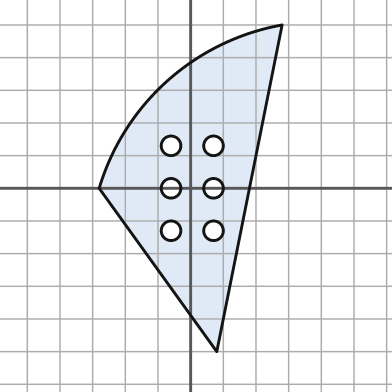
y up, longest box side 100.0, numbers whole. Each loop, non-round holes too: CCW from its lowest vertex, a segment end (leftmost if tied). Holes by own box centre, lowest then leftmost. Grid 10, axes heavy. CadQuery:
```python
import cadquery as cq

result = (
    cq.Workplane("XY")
    .moveTo(8.0, -50.0)
    .lineTo(28.0, 50.0)
    .threePointArc((-7.0, 33.0), (-28.0, 0.0))
    .close()
    .moveTo(-6.0, -13.0)
    .circle(3.0)
    .moveTo(7.0, -13.0)
    .circle(3.0)
    .moveTo(-6.0, 0.0)
    .circle(3.0)
    .moveTo(7.0, 0.0)
    .circle(3.0)
    .moveTo(-6.0, 13.0)
    .circle(3.0)
    .moveTo(7.0, 13.0)
    .circle(3.0)
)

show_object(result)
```